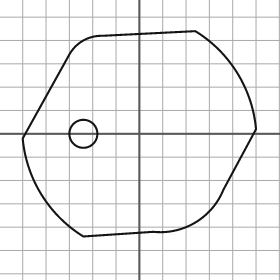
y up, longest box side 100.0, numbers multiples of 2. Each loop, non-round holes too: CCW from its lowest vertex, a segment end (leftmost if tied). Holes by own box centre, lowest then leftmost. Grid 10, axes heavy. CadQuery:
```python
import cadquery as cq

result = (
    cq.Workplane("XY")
    .moveTo(-24.0, -44.0)
    .lineTo(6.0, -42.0)
    .threePointArc((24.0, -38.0), (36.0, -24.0))
    .lineTo(50.0, 2.0)
    .threePointArc((42.0, 26.0), (24.0, 44.0))
    .lineTo(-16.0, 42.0)
    .threePointArc((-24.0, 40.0), (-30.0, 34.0))
    .lineTo(-50.0, -2.0)
    .threePointArc((-42.0, -26.0), (-24.0, -44.0))
    .close()
    .moveTo(-24.0, 0.0)
    .circle(6.0)
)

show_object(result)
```